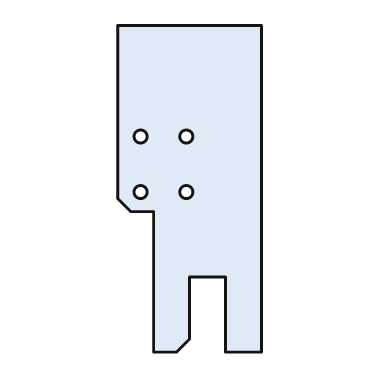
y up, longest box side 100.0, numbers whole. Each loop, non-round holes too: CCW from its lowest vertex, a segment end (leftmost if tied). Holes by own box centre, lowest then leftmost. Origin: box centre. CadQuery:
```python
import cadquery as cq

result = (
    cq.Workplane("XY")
    .moveTo(-11.0, -50.0)
    .lineTo(-4.0, -50.0)
    .lineTo(0.0, -46.0)
    .lineTo(0.0, -27.0)
    .lineTo(11.0, -27.0)
    .lineTo(11.0, -50.0)
    .lineTo(22.0, -50.0)
    .lineTo(22.0, 50.0)
    .lineTo(-22.0, 50.0)
    .lineTo(-22.0, -3.0)
    .lineTo(-18.0, -7.0)
    .lineTo(-11.0, -7.0)
    .close()
    .moveTo(-15.0, -1.0)
    .circle(2.0)
    .moveTo(-1.0, -1.0)
    .circle(2.0)
    .moveTo(-15.0, 16.0)
    .circle(2.0)
    .moveTo(-1.0, 16.0)
    .circle(2.0)
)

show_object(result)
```